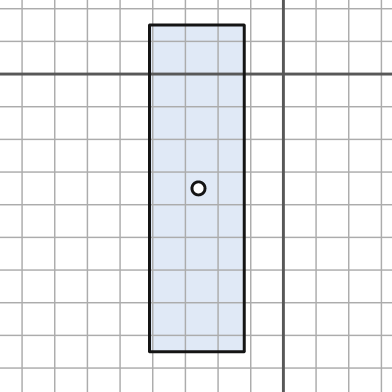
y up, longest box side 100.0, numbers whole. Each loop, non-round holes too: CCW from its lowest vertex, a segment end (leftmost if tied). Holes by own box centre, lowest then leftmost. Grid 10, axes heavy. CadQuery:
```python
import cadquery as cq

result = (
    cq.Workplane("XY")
    .moveTo(-41.0, -85.0)
    .lineTo(-12.0, -85.0)
    .lineTo(-12.0, 15.0)
    .lineTo(-41.0, 15.0)
    .close()
    .moveTo(-26.0, -35.0)
    .circle(2.0)
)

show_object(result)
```